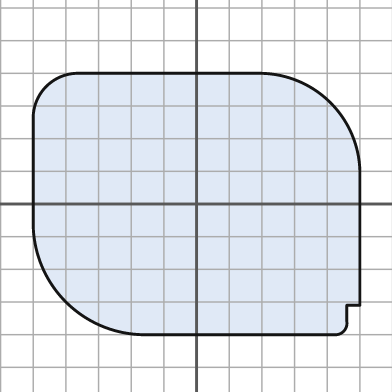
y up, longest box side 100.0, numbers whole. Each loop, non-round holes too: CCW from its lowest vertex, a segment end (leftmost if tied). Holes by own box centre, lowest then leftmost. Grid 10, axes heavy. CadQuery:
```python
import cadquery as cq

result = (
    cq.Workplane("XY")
    .moveTo(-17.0, -40.0)
    .lineTo(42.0, -40.0)
    .threePointArc((45.0, -39.0), (46.0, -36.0))
    .lineTo(46.0, -31.0)
    .lineTo(50.0, -31.0)
    .lineTo(50.0, 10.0)
    .threePointArc((41.0, 31.0), (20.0, 40.0))
    .lineTo(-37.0, 40.0)
    .threePointArc((-46.0, 36.0), (-50.0, 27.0))
    .lineTo(-50.0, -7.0)
    .threePointArc((-40.0, -30.0), (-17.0, -40.0))
    .close()
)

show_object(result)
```